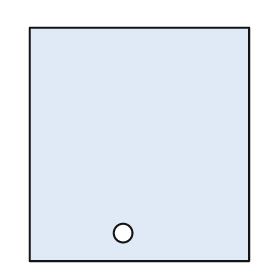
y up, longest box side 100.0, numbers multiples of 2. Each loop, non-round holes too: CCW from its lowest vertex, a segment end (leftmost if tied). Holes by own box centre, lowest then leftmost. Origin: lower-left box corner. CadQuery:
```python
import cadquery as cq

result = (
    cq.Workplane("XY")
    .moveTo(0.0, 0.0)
    .lineTo(94.0, 0.0)
    .lineTo(94.0, 100.0)
    .lineTo(0.0, 100.0)
    .close()
    .moveTo(40.0, 12.0)
    .circle(4.0)
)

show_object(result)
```